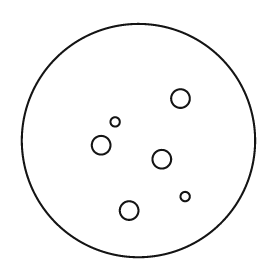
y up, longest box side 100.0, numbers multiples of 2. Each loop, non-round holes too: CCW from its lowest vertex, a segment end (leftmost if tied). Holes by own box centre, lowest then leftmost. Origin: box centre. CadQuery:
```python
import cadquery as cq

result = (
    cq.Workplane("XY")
    .moveTo(0.0, 0.0)
    .circle(50.0)
    .moveTo(-4.0, -30.0)
    .circle(4.0)
    .moveTo(20.0, -24.0)
    .circle(2.0)
    .moveTo(10.0, -8.0)
    .circle(4.0)
    .moveTo(-16.0, -2.0)
    .circle(4.0)
    .moveTo(-10.0, 8.0)
    .circle(2.0)
    .moveTo(18.0, 18.0)
    .circle(4.0)
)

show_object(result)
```